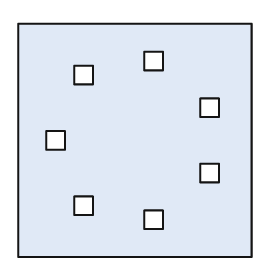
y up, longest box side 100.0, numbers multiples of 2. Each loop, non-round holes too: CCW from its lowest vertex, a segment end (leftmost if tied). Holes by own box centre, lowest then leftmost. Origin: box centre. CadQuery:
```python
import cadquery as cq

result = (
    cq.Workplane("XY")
    .moveTo(-50.0, -50.0)
    .lineTo(50.0, -50.0)
    .lineTo(50.0, 50.0)
    .lineTo(-50.0, 50.0)
    .close()
    .moveTo(4.0, -38.0)
    .lineTo(12.0, -38.0)
    .lineTo(12.0, -30.0)
    .lineTo(4.0, -30.0)
    .close()
    .moveTo(-26.0, -32.0)
    .lineTo(-18.0, -32.0)
    .lineTo(-18.0, -24.0)
    .lineTo(-26.0, -24.0)
    .close()
    .moveTo(28.0, -18.0)
    .lineTo(36.0, -18.0)
    .lineTo(36.0, -10.0)
    .lineTo(28.0, -10.0)
    .close()
    .moveTo(-38.0, -4.0)
    .lineTo(-30.0, -4.0)
    .lineTo(-30.0, 4.0)
    .lineTo(-38.0, 4.0)
    .close()
    .moveTo(28.0, 10.0)
    .lineTo(36.0, 10.0)
    .lineTo(36.0, 18.0)
    .lineTo(28.0, 18.0)
    .close()
    .moveTo(-26.0, 24.0)
    .lineTo(-18.0, 24.0)
    .lineTo(-18.0, 32.0)
    .lineTo(-26.0, 32.0)
    .close()
    .moveTo(4.0, 30.0)
    .lineTo(12.0, 30.0)
    .lineTo(12.0, 38.0)
    .lineTo(4.0, 38.0)
    .close()
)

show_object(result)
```